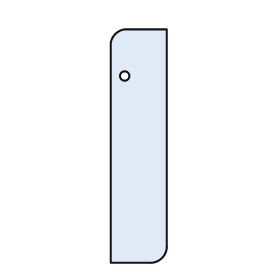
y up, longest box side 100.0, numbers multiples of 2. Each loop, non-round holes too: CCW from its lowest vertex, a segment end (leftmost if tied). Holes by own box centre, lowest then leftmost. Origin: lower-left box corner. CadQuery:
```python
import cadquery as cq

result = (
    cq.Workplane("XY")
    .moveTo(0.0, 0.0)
    .lineTo(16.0, 0.0)
    .threePointArc((22.0, 2.0), (24.0, 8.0))
    .lineTo(24.0, 100.0)
    .lineTo(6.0, 100.0)
    .threePointArc((2.0, 98.0), (0.0, 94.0))
    .close()
    .moveTo(6.0, 80.0)
    .circle(2.0)
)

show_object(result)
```